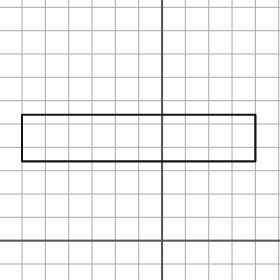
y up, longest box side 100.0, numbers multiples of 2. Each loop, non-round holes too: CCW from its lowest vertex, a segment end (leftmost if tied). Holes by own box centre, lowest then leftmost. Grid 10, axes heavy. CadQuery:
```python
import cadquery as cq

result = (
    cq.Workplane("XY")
    .moveTo(-60.0, 34.0)
    .lineTo(40.0, 34.0)
    .lineTo(40.0, 54.0)
    .lineTo(-60.0, 54.0)
    .close()
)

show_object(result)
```